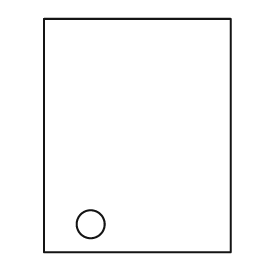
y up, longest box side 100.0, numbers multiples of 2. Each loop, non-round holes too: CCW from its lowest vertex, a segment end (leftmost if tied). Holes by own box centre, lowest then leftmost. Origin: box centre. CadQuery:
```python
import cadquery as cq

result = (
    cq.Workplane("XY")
    .moveTo(-40.0, -50.0)
    .lineTo(40.0, -50.0)
    .lineTo(40.0, 50.0)
    .lineTo(-40.0, 50.0)
    .close()
    .moveTo(-20.0, -38.0)
    .circle(6.0)
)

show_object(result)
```